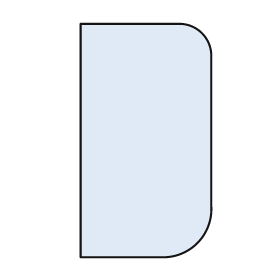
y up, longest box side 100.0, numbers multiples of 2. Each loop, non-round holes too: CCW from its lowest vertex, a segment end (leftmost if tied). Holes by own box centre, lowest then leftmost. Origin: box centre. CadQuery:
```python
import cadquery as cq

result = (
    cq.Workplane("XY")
    .moveTo(-28.0, -50.0)
    .lineTo(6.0, -50.0)
    .threePointArc((22.0, -44.0), (28.0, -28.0))
    .lineTo(28.0, 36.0)
    .threePointArc((24.0, 46.0), (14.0, 50.0))
    .lineTo(-28.0, 50.0)
    .close()
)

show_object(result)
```